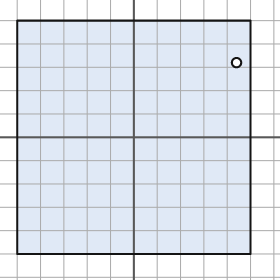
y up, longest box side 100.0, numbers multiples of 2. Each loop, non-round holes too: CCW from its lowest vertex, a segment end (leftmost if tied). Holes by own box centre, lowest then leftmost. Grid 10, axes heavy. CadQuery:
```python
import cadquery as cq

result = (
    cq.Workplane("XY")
    .moveTo(-50.0, -50.0)
    .lineTo(50.0, -50.0)
    .lineTo(50.0, 50.0)
    .lineTo(-50.0, 50.0)
    .close()
    .moveTo(44.0, 32.0)
    .circle(2.0)
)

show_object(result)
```